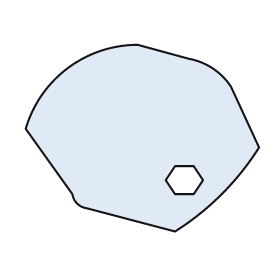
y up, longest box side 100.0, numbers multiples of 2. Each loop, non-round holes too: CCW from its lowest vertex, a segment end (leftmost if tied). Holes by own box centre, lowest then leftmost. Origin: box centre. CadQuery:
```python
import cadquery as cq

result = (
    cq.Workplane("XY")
    .moveTo(14.0, -40.0)
    .threePointArc((34.0, -24.0), (50.0, -4.0))
    .lineTo(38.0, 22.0)
    .threePointArc((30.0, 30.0), (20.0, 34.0))
    .lineTo(-2.0, 40.0)
    .threePointArc((-32.0, 30.0), (-50.0, 4.0))
    .lineTo(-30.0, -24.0)
    .threePointArc((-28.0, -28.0), (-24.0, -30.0))
    .close()
    .moveTo(14.0, -24.0)
    .lineTo(22.0, -24.0)
    .lineTo(26.0, -18.0)
    .lineTo(22.0, -12.0)
    .lineTo(14.0, -12.0)
    .lineTo(10.0, -18.0)
    .close()
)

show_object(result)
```